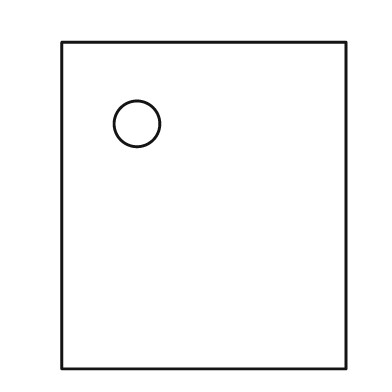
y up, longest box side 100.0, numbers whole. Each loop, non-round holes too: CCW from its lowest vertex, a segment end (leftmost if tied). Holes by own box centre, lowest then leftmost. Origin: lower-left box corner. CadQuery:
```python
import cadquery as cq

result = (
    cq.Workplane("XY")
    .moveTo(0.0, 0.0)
    .lineTo(87.0, 0.0)
    .lineTo(87.0, 100.0)
    .lineTo(0.0, 100.0)
    .close()
    .moveTo(23.0, 75.0)
    .circle(7.0)
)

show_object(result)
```